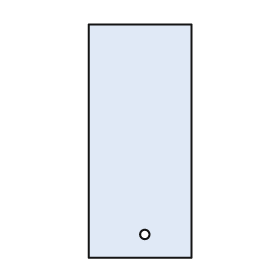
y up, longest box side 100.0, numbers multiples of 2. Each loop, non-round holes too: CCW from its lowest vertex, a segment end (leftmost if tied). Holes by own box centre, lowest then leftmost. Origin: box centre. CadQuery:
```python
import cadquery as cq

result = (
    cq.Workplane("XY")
    .moveTo(-22.0, -50.0)
    .lineTo(22.0, -50.0)
    .lineTo(22.0, 50.0)
    .lineTo(-22.0, 50.0)
    .close()
    .moveTo(2.0, -40.0)
    .circle(2.0)
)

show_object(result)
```